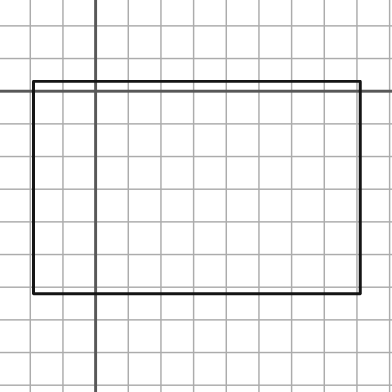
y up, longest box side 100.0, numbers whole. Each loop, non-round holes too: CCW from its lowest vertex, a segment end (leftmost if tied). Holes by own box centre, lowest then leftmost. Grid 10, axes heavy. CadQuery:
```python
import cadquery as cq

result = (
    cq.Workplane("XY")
    .moveTo(-19.0, -62.0)
    .lineTo(81.0, -62.0)
    .lineTo(81.0, 3.0)
    .lineTo(-19.0, 3.0)
    .close()
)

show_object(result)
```